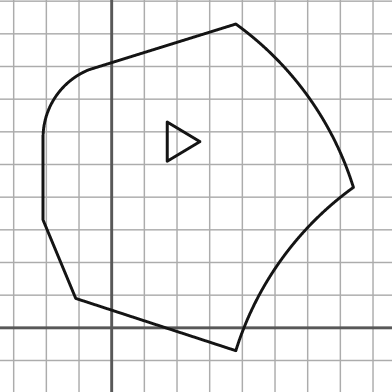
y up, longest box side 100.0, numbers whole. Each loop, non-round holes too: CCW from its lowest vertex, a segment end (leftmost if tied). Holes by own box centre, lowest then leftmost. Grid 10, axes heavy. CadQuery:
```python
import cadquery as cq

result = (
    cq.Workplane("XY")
    .moveTo(38.0, -7.0)
    .threePointArc((52.0, 21.0), (74.0, 43.0))
    .threePointArc((60.0, 71.0), (38.0, 93.0))
    .lineTo(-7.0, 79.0)
    .threePointArc((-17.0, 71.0), (-21.0, 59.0))
    .lineTo(-21.0, 33.0)
    .lineTo(-11.0, 9.0)
    .close()
    .moveTo(17.0, 51.0)
    .lineTo(27.0, 57.0)
    .lineTo(17.0, 63.0)
    .close()
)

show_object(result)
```